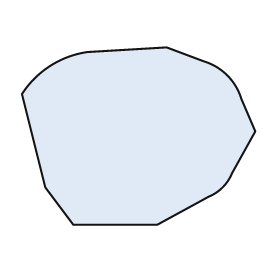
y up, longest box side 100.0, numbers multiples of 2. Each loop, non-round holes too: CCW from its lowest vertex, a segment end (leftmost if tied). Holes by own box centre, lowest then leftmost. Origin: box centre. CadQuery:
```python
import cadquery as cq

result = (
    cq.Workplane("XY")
    .moveTo(-28.0, -38.0)
    .lineTo(8.0, -38.0)
    .lineTo(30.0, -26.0)
    .threePointArc((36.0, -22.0), (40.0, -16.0))
    .lineTo(50.0, 2.0)
    .lineTo(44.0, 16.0)
    .threePointArc((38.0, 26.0), (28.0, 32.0))
    .lineTo(12.0, 38.0)
    .lineTo(-22.0, 36.0)
    .threePointArc((-38.0, 30.0), (-50.0, 18.0))
    .lineTo(-40.0, -22.0)
    .close()
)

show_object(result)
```